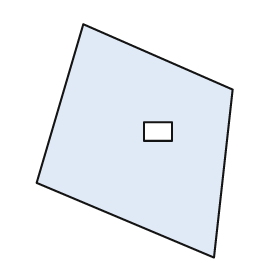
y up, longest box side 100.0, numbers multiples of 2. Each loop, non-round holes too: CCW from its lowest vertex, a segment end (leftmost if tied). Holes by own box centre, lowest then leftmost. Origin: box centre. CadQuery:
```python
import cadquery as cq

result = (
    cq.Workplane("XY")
    .moveTo(34.0, -50.0)
    .lineTo(42.0, 22.0)
    .lineTo(-22.0, 50.0)
    .lineTo(-42.0, -18.0)
    .close()
    .moveTo(4.0, 0.0)
    .lineTo(16.0, 0.0)
    .lineTo(16.0, 8.0)
    .lineTo(4.0, 8.0)
    .close()
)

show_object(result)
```